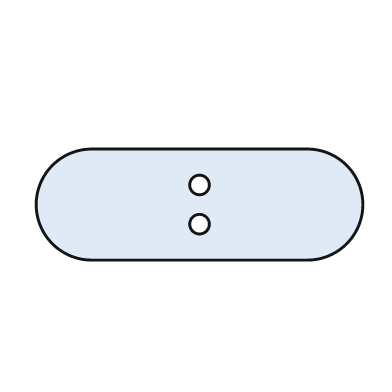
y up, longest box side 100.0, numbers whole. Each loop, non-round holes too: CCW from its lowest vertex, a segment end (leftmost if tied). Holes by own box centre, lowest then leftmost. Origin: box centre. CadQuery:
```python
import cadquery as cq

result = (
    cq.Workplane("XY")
    .moveTo(-33.0, -17.0)
    .lineTo(33.0, -17.0)
    .threePointArc((50.0, 0.0), (33.0, 17.0))
    .lineTo(-33.0, 17.0)
    .threePointArc((-50.0, 0.0), (-33.0, -17.0))
    .close()
    .moveTo(0.0, -6.0)
    .circle(3.0)
    .moveTo(0.0, 6.0)
    .circle(3.0)
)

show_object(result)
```